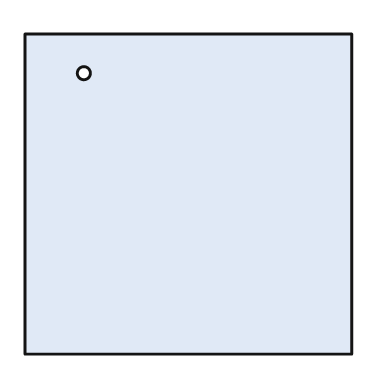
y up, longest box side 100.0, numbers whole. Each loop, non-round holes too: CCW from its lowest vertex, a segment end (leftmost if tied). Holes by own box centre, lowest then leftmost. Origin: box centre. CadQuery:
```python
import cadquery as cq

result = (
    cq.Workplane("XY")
    .moveTo(-50.0, -49.0)
    .lineTo(50.0, -49.0)
    .lineTo(50.0, 49.0)
    .lineTo(-50.0, 49.0)
    .close()
    .moveTo(-32.0, 37.0)
    .circle(2.0)
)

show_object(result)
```